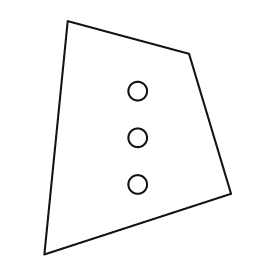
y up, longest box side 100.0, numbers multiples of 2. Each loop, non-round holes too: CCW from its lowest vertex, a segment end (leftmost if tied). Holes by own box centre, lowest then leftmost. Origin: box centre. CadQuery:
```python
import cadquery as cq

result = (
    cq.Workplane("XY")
    .moveTo(-40.0, -50.0)
    .lineTo(40.0, -24.0)
    .lineTo(22.0, 36.0)
    .lineTo(-30.0, 50.0)
    .close()
    .moveTo(0.0, -20.0)
    .circle(4.0)
    .moveTo(0.0, 0.0)
    .circle(4.0)
    .moveTo(0.0, 20.0)
    .circle(4.0)
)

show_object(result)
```